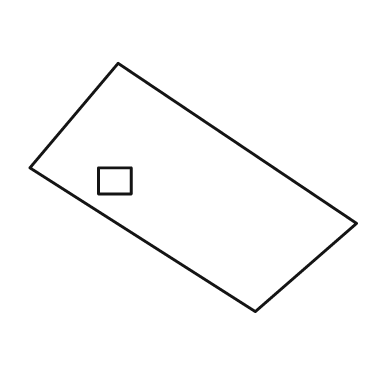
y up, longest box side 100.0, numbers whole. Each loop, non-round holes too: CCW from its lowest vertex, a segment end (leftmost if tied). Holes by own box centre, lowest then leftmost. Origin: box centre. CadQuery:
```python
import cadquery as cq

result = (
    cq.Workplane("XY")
    .moveTo(19.0, -38.0)
    .lineTo(50.0, -11.0)
    .lineTo(-23.0, 38.0)
    .lineTo(-50.0, 6.0)
    .close()
    .moveTo(-29.0, -2.0)
    .lineTo(-19.0, -2.0)
    .lineTo(-19.0, 6.0)
    .lineTo(-29.0, 6.0)
    .close()
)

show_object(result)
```